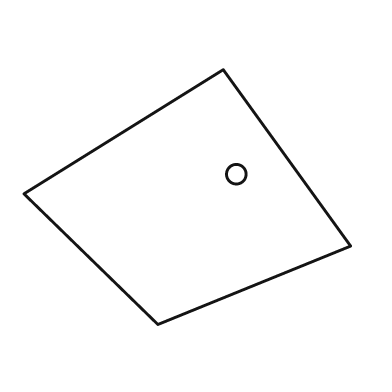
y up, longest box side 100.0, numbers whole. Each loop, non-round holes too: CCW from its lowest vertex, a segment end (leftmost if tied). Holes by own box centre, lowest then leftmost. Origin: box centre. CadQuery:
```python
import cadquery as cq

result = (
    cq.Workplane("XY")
    .moveTo(-9.0, -39.0)
    .lineTo(50.0, -15.0)
    .lineTo(11.0, 39.0)
    .lineTo(-50.0, 1.0)
    .close()
    .moveTo(15.0, 7.0)
    .circle(3.0)
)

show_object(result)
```